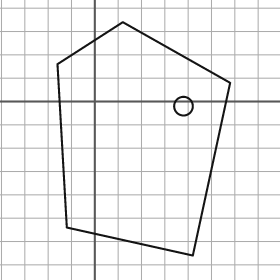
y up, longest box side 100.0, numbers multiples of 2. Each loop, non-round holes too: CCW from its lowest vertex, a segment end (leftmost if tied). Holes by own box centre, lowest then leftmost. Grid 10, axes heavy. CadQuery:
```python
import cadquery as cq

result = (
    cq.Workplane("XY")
    .moveTo(42.0, -66.0)
    .lineTo(58.0, 8.0)
    .lineTo(12.0, 34.0)
    .lineTo(-16.0, 16.0)
    .lineTo(-12.0, -54.0)
    .close()
    .moveTo(38.0, -2.0)
    .circle(4.0)
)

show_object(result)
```